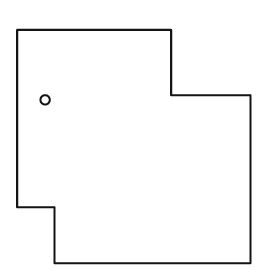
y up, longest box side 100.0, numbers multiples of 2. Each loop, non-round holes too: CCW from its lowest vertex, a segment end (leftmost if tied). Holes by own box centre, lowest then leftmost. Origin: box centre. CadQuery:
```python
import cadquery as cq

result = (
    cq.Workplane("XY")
    .moveTo(-34.0, -50.0)
    .lineTo(50.0, -50.0)
    .lineTo(50.0, 22.0)
    .lineTo(16.0, 22.0)
    .lineTo(16.0, 50.0)
    .lineTo(-50.0, 50.0)
    .lineTo(-50.0, -26.0)
    .lineTo(-34.0, -26.0)
    .close()
    .moveTo(-38.0, 20.0)
    .circle(2.0)
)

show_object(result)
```